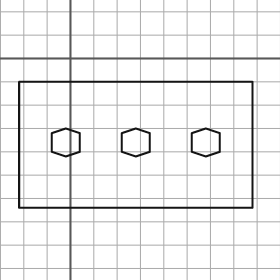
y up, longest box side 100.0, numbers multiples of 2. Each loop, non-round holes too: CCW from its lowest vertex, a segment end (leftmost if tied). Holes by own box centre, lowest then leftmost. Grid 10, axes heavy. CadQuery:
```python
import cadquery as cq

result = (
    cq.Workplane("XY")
    .moveTo(-22.0, -64.0)
    .lineTo(78.0, -64.0)
    .lineTo(78.0, -10.0)
    .lineTo(-22.0, -10.0)
    .close()
    .moveTo(-2.0, -42.0)
    .lineTo(4.0, -40.0)
    .lineTo(4.0, -32.0)
    .lineTo(-2.0, -30.0)
    .lineTo(-8.0, -32.0)
    .lineTo(-8.0, -40.0)
    .close()
    .moveTo(28.0, -42.0)
    .lineTo(34.0, -40.0)
    .lineTo(34.0, -32.0)
    .lineTo(28.0, -30.0)
    .lineTo(22.0, -32.0)
    .lineTo(22.0, -40.0)
    .close()
    .moveTo(58.0, -42.0)
    .lineTo(64.0, -40.0)
    .lineTo(64.0, -32.0)
    .lineTo(58.0, -30.0)
    .lineTo(52.0, -32.0)
    .lineTo(52.0, -40.0)
    .close()
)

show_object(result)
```